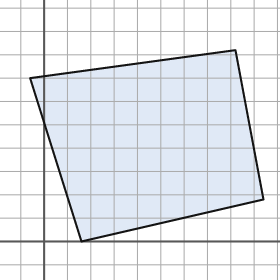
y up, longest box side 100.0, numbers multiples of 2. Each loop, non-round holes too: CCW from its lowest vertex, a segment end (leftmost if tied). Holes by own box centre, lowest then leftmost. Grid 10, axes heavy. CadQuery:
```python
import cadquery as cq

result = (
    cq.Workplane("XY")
    .moveTo(16.0, 0.0)
    .lineTo(94.0, 18.0)
    .lineTo(82.0, 82.0)
    .lineTo(-6.0, 70.0)
    .close()
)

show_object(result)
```